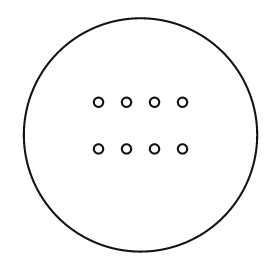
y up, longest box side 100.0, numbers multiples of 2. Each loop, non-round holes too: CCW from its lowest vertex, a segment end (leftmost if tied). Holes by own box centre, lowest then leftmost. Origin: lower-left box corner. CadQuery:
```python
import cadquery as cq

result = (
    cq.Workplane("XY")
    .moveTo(50.0, 50.0)
    .circle(50.0)
    .moveTo(32.0, 44.0)
    .circle(2.0)
    .moveTo(44.0, 44.0)
    .circle(2.0)
    .moveTo(56.0, 44.0)
    .circle(2.0)
    .moveTo(68.0, 44.0)
    .circle(2.0)
    .moveTo(32.0, 64.0)
    .circle(2.0)
    .moveTo(44.0, 64.0)
    .circle(2.0)
    .moveTo(56.0, 64.0)
    .circle(2.0)
    .moveTo(68.0, 64.0)
    .circle(2.0)
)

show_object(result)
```